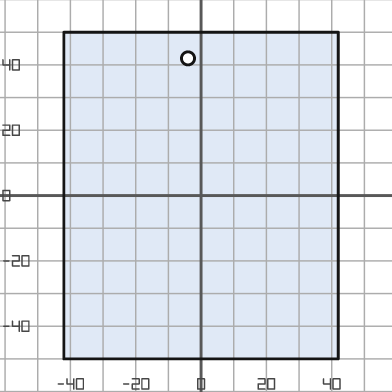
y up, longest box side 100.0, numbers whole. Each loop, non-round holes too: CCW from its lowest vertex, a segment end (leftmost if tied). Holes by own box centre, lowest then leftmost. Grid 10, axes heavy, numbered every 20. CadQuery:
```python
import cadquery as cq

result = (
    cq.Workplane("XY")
    .moveTo(-42.0, -50.0)
    .lineTo(42.0, -50.0)
    .lineTo(42.0, 50.0)
    .lineTo(-42.0, 50.0)
    .close()
    .moveTo(-4.0, 42.0)
    .circle(2.0)
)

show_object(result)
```